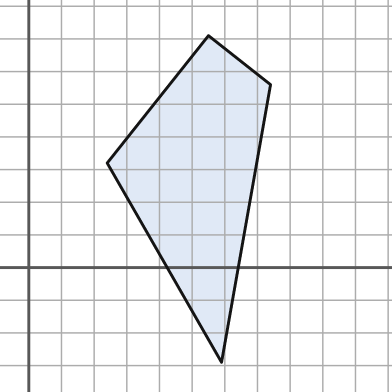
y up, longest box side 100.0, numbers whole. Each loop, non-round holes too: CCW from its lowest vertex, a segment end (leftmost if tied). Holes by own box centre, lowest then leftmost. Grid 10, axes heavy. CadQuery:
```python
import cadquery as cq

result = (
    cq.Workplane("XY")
    .moveTo(59.0, -29.0)
    .lineTo(74.0, 56.0)
    .lineTo(55.0, 71.0)
    .lineTo(24.0, 32.0)
    .close()
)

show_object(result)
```